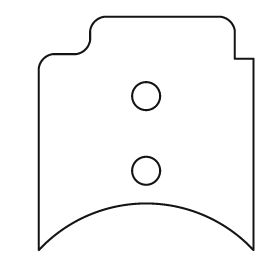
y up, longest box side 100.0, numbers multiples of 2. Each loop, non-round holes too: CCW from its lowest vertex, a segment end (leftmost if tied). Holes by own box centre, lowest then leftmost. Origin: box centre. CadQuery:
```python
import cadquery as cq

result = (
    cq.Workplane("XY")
    .moveTo(-46.0, -50.0)
    .threePointArc((0.0, -30.0), (46.0, -50.0))
    .lineTo(46.0, 32.0)
    .lineTo(38.0, 32.0)
    .lineTo(38.0, 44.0)
    .threePointArc((36.0, 48.0), (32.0, 50.0))
    .lineTo(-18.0, 50.0)
    .threePointArc((-22.0, 48.0), (-24.0, 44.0))
    .lineTo(-24.0, 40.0)
    .threePointArc((-26.0, 36.0), (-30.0, 34.0))
    .lineTo(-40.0, 34.0)
    .threePointArc((-44.0, 32.0), (-46.0, 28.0))
    .close()
    .moveTo(0.0, -16.0)
    .circle(6.0)
    .moveTo(0.0, 16.0)
    .circle(6.0)
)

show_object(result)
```